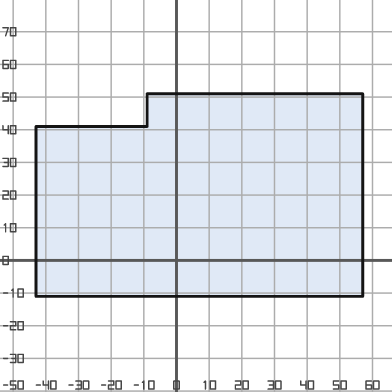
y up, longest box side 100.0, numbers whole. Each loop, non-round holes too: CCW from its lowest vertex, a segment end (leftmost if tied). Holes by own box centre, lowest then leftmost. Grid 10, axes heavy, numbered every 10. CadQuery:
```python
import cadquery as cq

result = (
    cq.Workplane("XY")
    .moveTo(-43.0, -11.0)
    .lineTo(57.0, -11.0)
    .lineTo(57.0, 51.0)
    .lineTo(-9.0, 51.0)
    .lineTo(-9.0, 41.0)
    .lineTo(-43.0, 41.0)
    .close()
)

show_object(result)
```